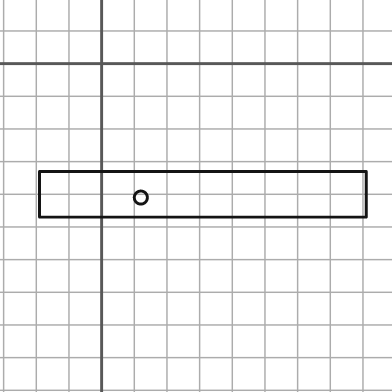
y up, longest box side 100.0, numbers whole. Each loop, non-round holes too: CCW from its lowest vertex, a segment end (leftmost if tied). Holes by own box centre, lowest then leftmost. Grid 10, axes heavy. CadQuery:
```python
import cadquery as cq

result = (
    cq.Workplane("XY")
    .moveTo(-19.0, -47.0)
    .lineTo(81.0, -47.0)
    .lineTo(81.0, -33.0)
    .lineTo(-19.0, -33.0)
    .close()
    .moveTo(12.0, -41.0)
    .circle(2.0)
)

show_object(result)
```